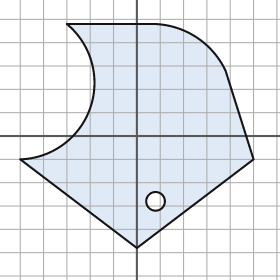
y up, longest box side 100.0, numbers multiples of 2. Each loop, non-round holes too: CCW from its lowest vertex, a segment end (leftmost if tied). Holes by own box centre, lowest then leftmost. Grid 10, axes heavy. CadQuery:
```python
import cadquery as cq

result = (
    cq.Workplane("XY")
    .moveTo(0.0, -48.0)
    .lineTo(50.0, -10.0)
    .lineTo(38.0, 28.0)
    .threePointArc((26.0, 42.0), (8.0, 48.0))
    .lineTo(-30.0, 48.0)
    .threePointArc((-20.0, 12.0), (-50.0, -10.0))
    .close()
    .moveTo(8.0, -28.0)
    .circle(4.0)
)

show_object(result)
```